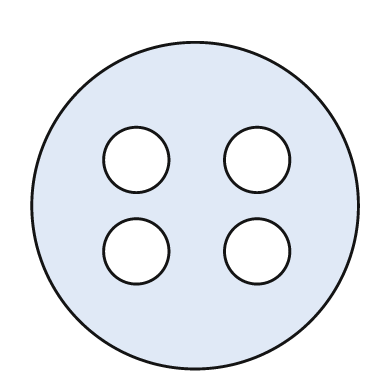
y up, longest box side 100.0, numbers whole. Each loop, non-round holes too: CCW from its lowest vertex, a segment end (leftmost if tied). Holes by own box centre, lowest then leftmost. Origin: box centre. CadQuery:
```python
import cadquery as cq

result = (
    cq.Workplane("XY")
    .moveTo(0.0, 0.0)
    .circle(50.0)
    .moveTo(-18.0, -14.0)
    .circle(10.0)
    .moveTo(19.0, -14.0)
    .circle(10.0)
    .moveTo(-18.0, 14.0)
    .circle(10.0)
    .moveTo(19.0, 14.0)
    .circle(10.0)
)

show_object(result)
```